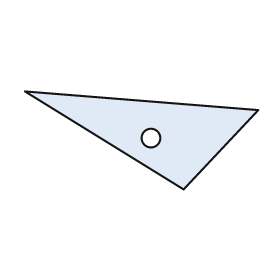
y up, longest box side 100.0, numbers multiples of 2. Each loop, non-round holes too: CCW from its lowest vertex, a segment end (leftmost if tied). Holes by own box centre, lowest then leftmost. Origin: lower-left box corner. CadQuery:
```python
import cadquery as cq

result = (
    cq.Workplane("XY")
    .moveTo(68.0, 0.0)
    .lineTo(100.0, 34.0)
    .lineTo(0.0, 42.0)
    .close()
    .moveTo(54.0, 22.0)
    .circle(4.0)
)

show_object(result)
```